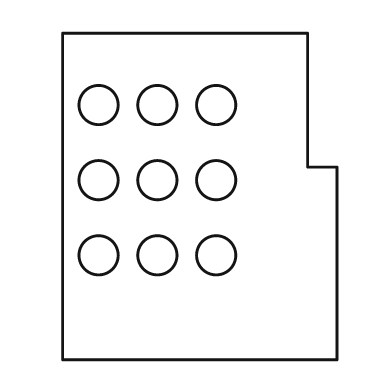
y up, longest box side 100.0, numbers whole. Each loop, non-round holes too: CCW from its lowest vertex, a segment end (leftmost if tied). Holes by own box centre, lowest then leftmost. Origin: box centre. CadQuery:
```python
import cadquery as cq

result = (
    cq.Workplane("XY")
    .moveTo(-42.0, -50.0)
    .lineTo(42.0, -50.0)
    .lineTo(42.0, 9.0)
    .lineTo(33.0, 9.0)
    .lineTo(33.0, 50.0)
    .lineTo(-42.0, 50.0)
    .close()
    .moveTo(-31.0, -18.0)
    .circle(6.0)
    .moveTo(-13.0, -18.0)
    .circle(6.0)
    .moveTo(5.0, -18.0)
    .circle(6.0)
    .moveTo(-31.0, 5.0)
    .circle(6.0)
    .moveTo(-13.0, 5.0)
    .circle(6.0)
    .moveTo(5.0, 5.0)
    .circle(6.0)
    .moveTo(-31.0, 28.0)
    .circle(6.0)
    .moveTo(-13.0, 28.0)
    .circle(6.0)
    .moveTo(5.0, 28.0)
    .circle(6.0)
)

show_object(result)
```